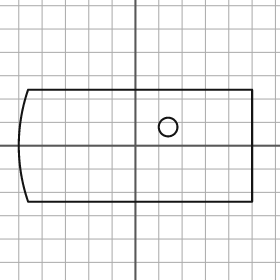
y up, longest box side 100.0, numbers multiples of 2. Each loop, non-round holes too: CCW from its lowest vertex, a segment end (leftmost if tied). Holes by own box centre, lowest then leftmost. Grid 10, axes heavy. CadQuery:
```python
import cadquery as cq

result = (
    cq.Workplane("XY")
    .moveTo(-46.0, -24.0)
    .lineTo(50.0, -24.0)
    .lineTo(50.0, 24.0)
    .lineTo(-46.0, 24.0)
    .threePointArc((-50.0, 0.0), (-46.0, -24.0))
    .close()
    .moveTo(14.0, 8.0)
    .circle(4.0)
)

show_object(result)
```